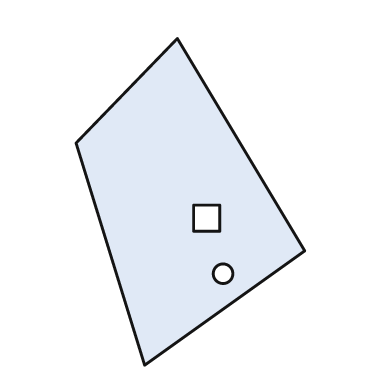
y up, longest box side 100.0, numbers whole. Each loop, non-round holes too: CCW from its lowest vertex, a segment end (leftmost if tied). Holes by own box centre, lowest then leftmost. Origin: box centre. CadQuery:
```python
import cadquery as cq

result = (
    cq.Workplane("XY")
    .moveTo(-14.0, -50.0)
    .lineTo(35.0, -15.0)
    .lineTo(-4.0, 50.0)
    .lineTo(-35.0, 18.0)
    .close()
    .moveTo(10.0, -22.0)
    .circle(3.0)
    .moveTo(1.0, -9.0)
    .lineTo(9.0, -9.0)
    .lineTo(9.0, -1.0)
    .lineTo(1.0, -1.0)
    .close()
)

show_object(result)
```